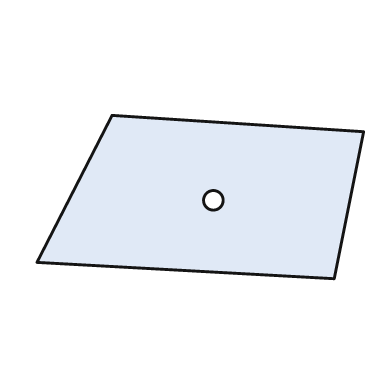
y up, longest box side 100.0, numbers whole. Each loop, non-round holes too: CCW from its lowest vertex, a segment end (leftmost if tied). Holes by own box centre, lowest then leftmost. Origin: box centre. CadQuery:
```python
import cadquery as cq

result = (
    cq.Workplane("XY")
    .moveTo(41.0, -25.0)
    .lineTo(50.0, 20.0)
    .lineTo(-27.0, 25.0)
    .lineTo(-50.0, -20.0)
    .close()
    .moveTo(4.0, -1.0)
    .circle(3.0)
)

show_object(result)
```